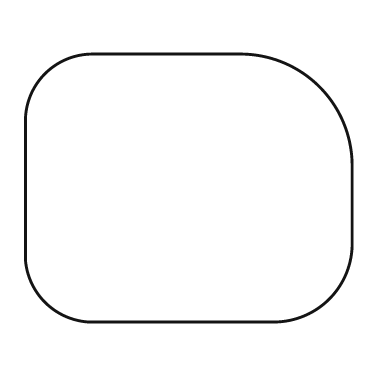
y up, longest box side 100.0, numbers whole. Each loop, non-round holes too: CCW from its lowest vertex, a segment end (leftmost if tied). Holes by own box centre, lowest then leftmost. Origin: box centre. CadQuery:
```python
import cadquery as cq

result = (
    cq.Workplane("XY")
    .moveTo(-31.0, -41.0)
    .lineTo(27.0, -41.0)
    .threePointArc((43.0, -34.0), (50.0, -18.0))
    .lineTo(50.0, 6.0)
    .threePointArc((40.0, 31.0), (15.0, 41.0))
    .lineTo(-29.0, 41.0)
    .threePointArc((-44.0, 35.0), (-50.0, 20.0))
    .lineTo(-50.0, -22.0)
    .threePointArc((-44.0, -35.0), (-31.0, -41.0))
    .close()
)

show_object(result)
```